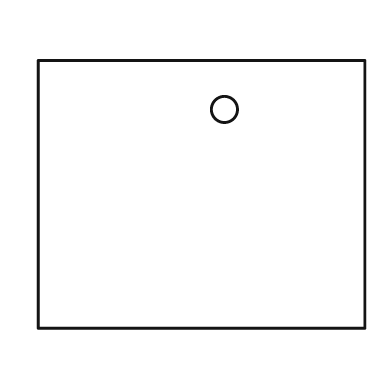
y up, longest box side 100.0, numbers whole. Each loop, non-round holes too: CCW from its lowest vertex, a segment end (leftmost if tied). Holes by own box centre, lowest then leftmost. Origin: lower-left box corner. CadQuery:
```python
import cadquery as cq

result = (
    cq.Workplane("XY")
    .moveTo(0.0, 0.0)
    .lineTo(100.0, 0.0)
    .lineTo(100.0, 82.0)
    .lineTo(0.0, 82.0)
    .close()
    .moveTo(57.0, 67.0)
    .circle(4.0)
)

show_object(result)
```